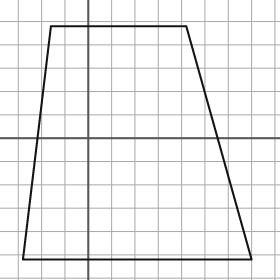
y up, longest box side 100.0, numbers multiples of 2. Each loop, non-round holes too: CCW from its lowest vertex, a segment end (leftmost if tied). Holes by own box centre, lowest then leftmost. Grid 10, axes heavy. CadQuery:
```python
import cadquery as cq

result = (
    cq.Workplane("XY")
    .moveTo(-28.0, -52.0)
    .lineTo(70.0, -52.0)
    .lineTo(42.0, 48.0)
    .lineTo(-16.0, 48.0)
    .close()
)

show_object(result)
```